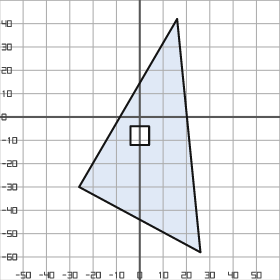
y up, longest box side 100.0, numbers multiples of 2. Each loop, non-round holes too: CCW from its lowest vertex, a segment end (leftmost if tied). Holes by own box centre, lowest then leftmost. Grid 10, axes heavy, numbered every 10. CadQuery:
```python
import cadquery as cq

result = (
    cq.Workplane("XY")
    .moveTo(26.0, -58.0)
    .lineTo(16.0, 42.0)
    .lineTo(-26.0, -30.0)
    .close()
    .moveTo(-4.0, -12.0)
    .lineTo(4.0, -12.0)
    .lineTo(4.0, -4.0)
    .lineTo(-4.0, -4.0)
    .close()
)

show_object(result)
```